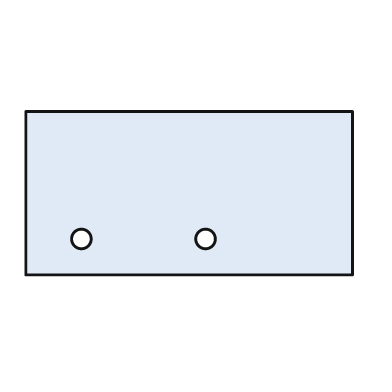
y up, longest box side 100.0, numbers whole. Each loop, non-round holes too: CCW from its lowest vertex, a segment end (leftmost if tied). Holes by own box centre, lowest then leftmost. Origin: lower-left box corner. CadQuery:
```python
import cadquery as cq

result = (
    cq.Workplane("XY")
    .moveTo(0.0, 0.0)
    .lineTo(100.0, 0.0)
    .lineTo(100.0, 50.0)
    .lineTo(0.0, 50.0)
    .close()
    .moveTo(17.0, 11.0)
    .circle(3.0)
    .moveTo(55.0, 11.0)
    .circle(3.0)
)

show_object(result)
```